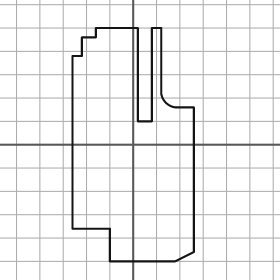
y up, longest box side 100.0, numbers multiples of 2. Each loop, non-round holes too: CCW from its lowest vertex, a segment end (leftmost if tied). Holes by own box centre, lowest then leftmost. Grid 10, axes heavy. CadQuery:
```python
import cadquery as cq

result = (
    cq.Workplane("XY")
    .moveTo(-10.0, -50.0)
    .lineTo(18.0, -50.0)
    .lineTo(26.0, -46.0)
    .lineTo(26.0, 16.0)
    .lineTo(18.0, 16.0)
    .threePointArc((14.0, 18.0), (12.0, 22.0))
    .lineTo(12.0, 50.0)
    .lineTo(8.0, 50.0)
    .lineTo(8.0, 10.0)
    .lineTo(2.0, 10.0)
    .lineTo(2.0, 50.0)
    .lineTo(-16.0, 50.0)
    .lineTo(-16.0, 46.0)
    .lineTo(-22.0, 46.0)
    .lineTo(-22.0, 38.0)
    .lineTo(-26.0, 38.0)
    .lineTo(-26.0, -36.0)
    .lineTo(-10.0, -36.0)
    .close()
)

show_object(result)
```